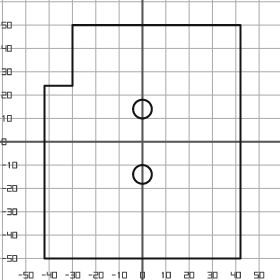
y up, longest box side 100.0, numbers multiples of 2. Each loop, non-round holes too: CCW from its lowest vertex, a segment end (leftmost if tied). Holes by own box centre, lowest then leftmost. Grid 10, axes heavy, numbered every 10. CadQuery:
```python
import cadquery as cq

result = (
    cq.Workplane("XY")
    .moveTo(-42.0, -50.0)
    .lineTo(42.0, -50.0)
    .lineTo(42.0, 50.0)
    .lineTo(-30.0, 50.0)
    .lineTo(-30.0, 24.0)
    .lineTo(-42.0, 24.0)
    .close()
    .moveTo(0.0, -14.0)
    .circle(4.0)
    .moveTo(0.0, 14.0)
    .circle(4.0)
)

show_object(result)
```